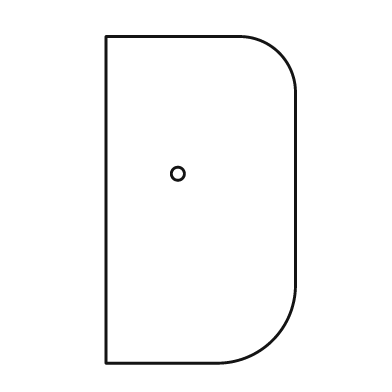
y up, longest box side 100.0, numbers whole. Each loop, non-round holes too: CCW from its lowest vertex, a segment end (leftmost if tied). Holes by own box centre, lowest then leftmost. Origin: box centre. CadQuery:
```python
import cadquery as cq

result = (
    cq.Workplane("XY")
    .moveTo(-29.0, -50.0)
    .lineTo(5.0, -50.0)
    .threePointArc((22.0, -43.0), (29.0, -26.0))
    .lineTo(29.0, 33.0)
    .threePointArc((24.0, 45.0), (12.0, 50.0))
    .lineTo(-29.0, 50.0)
    .close()
    .moveTo(-7.0, 8.0)
    .circle(2.0)
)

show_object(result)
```